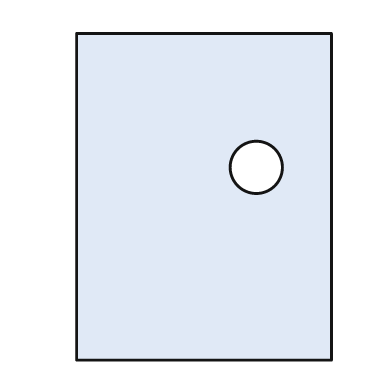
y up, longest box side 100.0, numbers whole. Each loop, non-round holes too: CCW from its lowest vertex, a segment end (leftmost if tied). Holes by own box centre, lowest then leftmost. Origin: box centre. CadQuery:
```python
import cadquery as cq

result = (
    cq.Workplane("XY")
    .moveTo(-39.0, -50.0)
    .lineTo(39.0, -50.0)
    .lineTo(39.0, 50.0)
    .lineTo(-39.0, 50.0)
    .close()
    .moveTo(16.0, 9.0)
    .circle(8.0)
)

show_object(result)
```